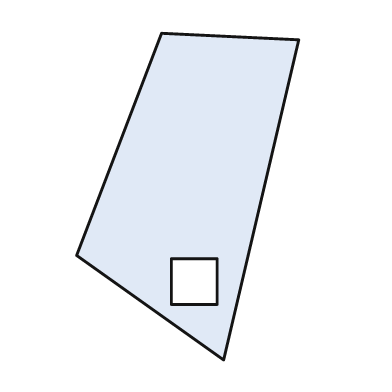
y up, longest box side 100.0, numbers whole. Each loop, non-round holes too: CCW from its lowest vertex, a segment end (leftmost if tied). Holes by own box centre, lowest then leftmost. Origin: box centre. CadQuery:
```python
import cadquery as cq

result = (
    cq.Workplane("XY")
    .moveTo(11.0, -50.0)
    .lineTo(34.0, 48.0)
    .lineTo(-8.0, 50.0)
    .lineTo(-34.0, -18.0)
    .close()
    .moveTo(-5.0, -33.0)
    .lineTo(9.0, -33.0)
    .lineTo(9.0, -19.0)
    .lineTo(-5.0, -19.0)
    .close()
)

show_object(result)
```